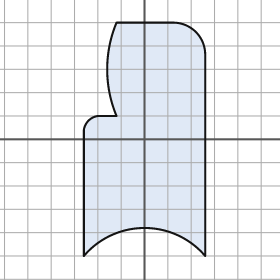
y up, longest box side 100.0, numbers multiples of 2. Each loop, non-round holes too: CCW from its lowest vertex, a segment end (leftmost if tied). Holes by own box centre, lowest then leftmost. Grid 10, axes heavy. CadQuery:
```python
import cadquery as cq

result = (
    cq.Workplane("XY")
    .moveTo(-26.0, -50.0)
    .threePointArc((0.0, -38.0), (26.0, -50.0))
    .lineTo(26.0, 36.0)
    .threePointArc((22.0, 46.0), (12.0, 50.0))
    .lineTo(-12.0, 50.0)
    .threePointArc((-16.0, 30.0), (-12.0, 10.0))
    .lineTo(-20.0, 10.0)
    .threePointArc((-24.0, 8.0), (-26.0, 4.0))
    .close()
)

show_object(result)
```